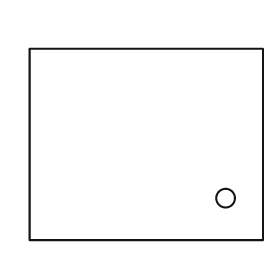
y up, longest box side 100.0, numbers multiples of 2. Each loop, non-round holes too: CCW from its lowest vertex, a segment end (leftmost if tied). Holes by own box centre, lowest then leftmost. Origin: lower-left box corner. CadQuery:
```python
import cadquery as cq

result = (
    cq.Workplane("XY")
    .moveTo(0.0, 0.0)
    .lineTo(100.0, 0.0)
    .lineTo(100.0, 82.0)
    .lineTo(0.0, 82.0)
    .close()
    .moveTo(84.0, 18.0)
    .circle(4.0)
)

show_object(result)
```